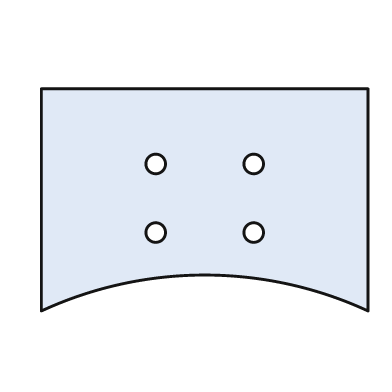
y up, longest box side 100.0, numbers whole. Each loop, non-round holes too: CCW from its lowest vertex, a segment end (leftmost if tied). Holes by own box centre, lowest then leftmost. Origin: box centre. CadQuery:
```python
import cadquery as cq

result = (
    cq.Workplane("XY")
    .moveTo(-50.0, -34.0)
    .threePointArc((0.0, -23.0), (50.0, -34.0))
    .lineTo(50.0, 34.0)
    .lineTo(-50.0, 34.0)
    .close()
    .moveTo(-15.0, -10.0)
    .circle(3.0)
    .moveTo(15.0, -10.0)
    .circle(3.0)
    .moveTo(-15.0, 11.0)
    .circle(3.0)
    .moveTo(15.0, 11.0)
    .circle(3.0)
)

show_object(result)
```